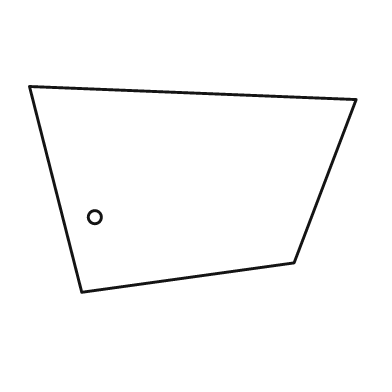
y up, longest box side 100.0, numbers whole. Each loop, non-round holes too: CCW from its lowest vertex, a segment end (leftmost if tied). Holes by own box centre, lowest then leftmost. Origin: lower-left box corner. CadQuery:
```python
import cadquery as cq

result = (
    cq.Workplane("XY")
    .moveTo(16.0, 0.0)
    .lineTo(81.0, 9.0)
    .lineTo(100.0, 59.0)
    .lineTo(0.0, 63.0)
    .close()
    .moveTo(20.0, 23.0)
    .circle(2.0)
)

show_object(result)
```